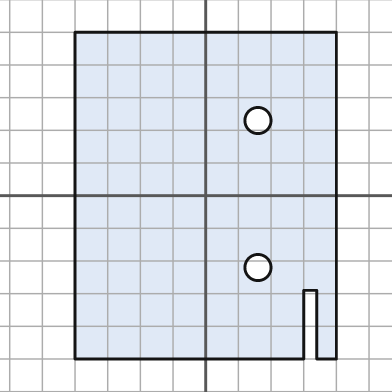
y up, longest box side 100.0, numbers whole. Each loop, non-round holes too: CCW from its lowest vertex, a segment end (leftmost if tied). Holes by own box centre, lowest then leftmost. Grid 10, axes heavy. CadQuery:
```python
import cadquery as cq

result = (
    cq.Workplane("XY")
    .moveTo(-40.0, -50.0)
    .lineTo(30.0, -50.0)
    .lineTo(30.0, -29.0)
    .lineTo(34.0, -29.0)
    .lineTo(34.0, -50.0)
    .lineTo(40.0, -50.0)
    .lineTo(40.0, 50.0)
    .lineTo(-40.0, 50.0)
    .close()
    .moveTo(16.0, -22.0)
    .circle(4.0)
    .moveTo(16.0, 23.0)
    .circle(4.0)
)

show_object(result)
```